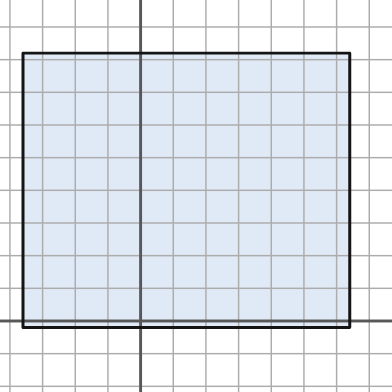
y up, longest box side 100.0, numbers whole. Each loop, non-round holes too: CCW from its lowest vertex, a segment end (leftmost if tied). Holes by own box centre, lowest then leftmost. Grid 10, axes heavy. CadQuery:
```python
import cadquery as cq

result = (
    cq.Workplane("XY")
    .moveTo(-36.0, -2.0)
    .lineTo(64.0, -2.0)
    .lineTo(64.0, 82.0)
    .lineTo(-36.0, 82.0)
    .close()
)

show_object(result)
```